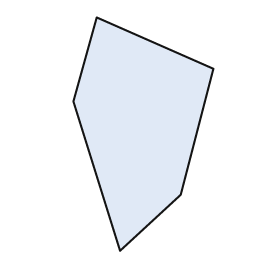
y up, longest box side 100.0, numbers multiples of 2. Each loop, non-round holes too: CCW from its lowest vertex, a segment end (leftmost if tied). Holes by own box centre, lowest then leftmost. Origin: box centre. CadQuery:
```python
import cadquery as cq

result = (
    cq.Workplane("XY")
    .moveTo(-10.0, -50.0)
    .lineTo(16.0, -26.0)
    .lineTo(30.0, 28.0)
    .lineTo(-20.0, 50.0)
    .lineTo(-30.0, 14.0)
    .close()
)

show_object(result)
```